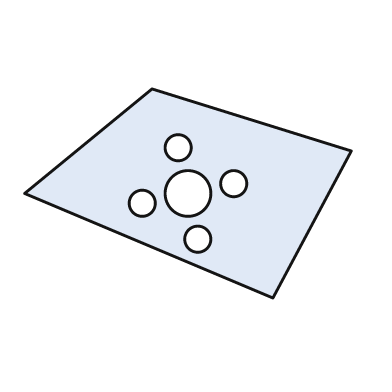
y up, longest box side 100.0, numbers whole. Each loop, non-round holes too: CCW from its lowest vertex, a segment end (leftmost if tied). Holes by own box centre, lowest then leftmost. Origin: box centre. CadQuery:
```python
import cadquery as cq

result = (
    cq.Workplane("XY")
    .moveTo(26.0, -32.0)
    .lineTo(50.0, 13.0)
    .lineTo(-11.0, 32.0)
    .lineTo(-50.0, 0.0)
    .close()
    .moveTo(3.0, -14.0)
    .circle(4.0)
    .moveTo(-14.0, -3.0)
    .circle(4.0)
    .moveTo(0.0, 0.0)
    .circle(7.0)
    .moveTo(14.0, 3.0)
    .circle(4.0)
    .moveTo(-3.0, 14.0)
    .circle(4.0)
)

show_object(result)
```